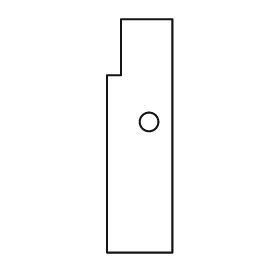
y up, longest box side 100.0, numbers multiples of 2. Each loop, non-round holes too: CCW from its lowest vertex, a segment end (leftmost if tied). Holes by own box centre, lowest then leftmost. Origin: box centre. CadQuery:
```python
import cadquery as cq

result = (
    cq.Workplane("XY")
    .moveTo(-14.0, -50.0)
    .lineTo(14.0, -50.0)
    .lineTo(14.0, 50.0)
    .lineTo(-8.0, 50.0)
    .lineTo(-8.0, 26.0)
    .lineTo(-14.0, 26.0)
    .close()
    .moveTo(4.0, 6.0)
    .circle(4.0)
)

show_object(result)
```